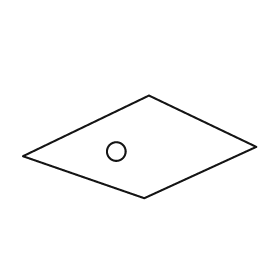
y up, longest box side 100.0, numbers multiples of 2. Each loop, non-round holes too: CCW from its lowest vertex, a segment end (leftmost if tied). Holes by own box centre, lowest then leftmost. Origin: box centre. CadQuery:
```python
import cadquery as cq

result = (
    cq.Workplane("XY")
    .moveTo(2.0, -22.0)
    .lineTo(50.0, 0.0)
    .lineTo(4.0, 22.0)
    .lineTo(-50.0, -4.0)
    .close()
    .moveTo(-10.0, -2.0)
    .circle(4.0)
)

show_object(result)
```